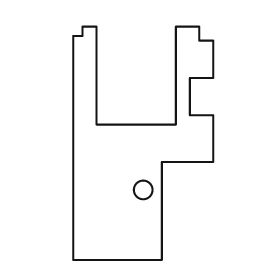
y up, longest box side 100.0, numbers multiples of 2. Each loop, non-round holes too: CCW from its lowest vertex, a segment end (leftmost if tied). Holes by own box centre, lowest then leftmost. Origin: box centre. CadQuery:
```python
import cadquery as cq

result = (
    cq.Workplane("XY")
    .moveTo(-30.0, -50.0)
    .lineTo(8.0, -50.0)
    .lineTo(8.0, -8.0)
    .lineTo(30.0, -8.0)
    .lineTo(30.0, 12.0)
    .lineTo(20.0, 12.0)
    .lineTo(20.0, 28.0)
    .lineTo(30.0, 28.0)
    .lineTo(30.0, 44.0)
    .lineTo(24.0, 44.0)
    .lineTo(24.0, 50.0)
    .lineTo(14.0, 50.0)
    .lineTo(14.0, 8.0)
    .lineTo(-20.0, 8.0)
    .lineTo(-20.0, 50.0)
    .lineTo(-26.0, 50.0)
    .lineTo(-26.0, 46.0)
    .lineTo(-30.0, 46.0)
    .close()
    .moveTo(0.0, -20.0)
    .circle(4.0)
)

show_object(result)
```